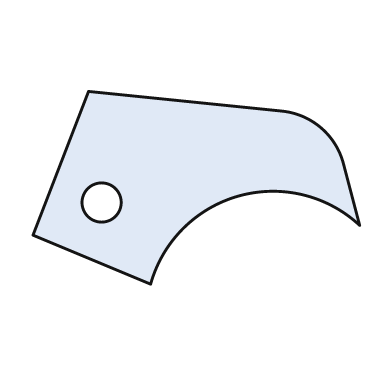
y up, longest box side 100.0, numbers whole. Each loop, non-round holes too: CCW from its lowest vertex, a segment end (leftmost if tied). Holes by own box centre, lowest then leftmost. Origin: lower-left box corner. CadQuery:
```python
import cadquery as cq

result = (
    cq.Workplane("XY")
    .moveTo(36.0, 0.0)
    .threePointArc((63.0, 27.0), (100.0, 18.0))
    .lineTo(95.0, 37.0)
    .threePointArc((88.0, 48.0), (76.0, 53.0))
    .lineTo(17.0, 59.0)
    .lineTo(0.0, 15.0)
    .close()
    .moveTo(21.0, 25.0)
    .circle(6.0)
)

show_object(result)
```